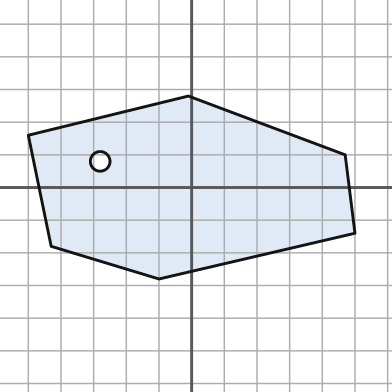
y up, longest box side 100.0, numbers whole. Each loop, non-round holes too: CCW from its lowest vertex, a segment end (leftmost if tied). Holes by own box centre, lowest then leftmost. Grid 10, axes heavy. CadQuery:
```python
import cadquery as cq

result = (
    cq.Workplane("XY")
    .moveTo(-10.0, -28.0)
    .lineTo(50.0, -14.0)
    .lineTo(47.0, 10.0)
    .lineTo(-1.0, 28.0)
    .lineTo(-50.0, 16.0)
    .lineTo(-43.0, -18.0)
    .close()
    .moveTo(-28.0, 8.0)
    .circle(3.0)
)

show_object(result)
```